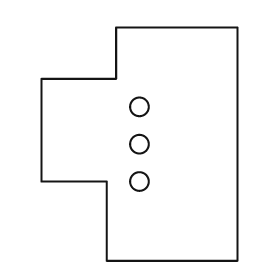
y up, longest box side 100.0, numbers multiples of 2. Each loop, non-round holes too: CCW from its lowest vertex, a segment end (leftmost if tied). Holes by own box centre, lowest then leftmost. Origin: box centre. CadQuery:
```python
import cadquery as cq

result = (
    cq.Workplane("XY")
    .moveTo(-14.0, -50.0)
    .lineTo(42.0, -50.0)
    .lineTo(42.0, 50.0)
    .lineTo(-10.0, 50.0)
    .lineTo(-10.0, 28.0)
    .lineTo(-42.0, 28.0)
    .lineTo(-42.0, -16.0)
    .lineTo(-14.0, -16.0)
    .close()
    .moveTo(0.0, -16.0)
    .circle(4.0)
    .moveTo(0.0, 0.0)
    .circle(4.0)
    .moveTo(0.0, 16.0)
    .circle(4.0)
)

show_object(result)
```